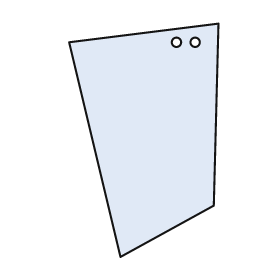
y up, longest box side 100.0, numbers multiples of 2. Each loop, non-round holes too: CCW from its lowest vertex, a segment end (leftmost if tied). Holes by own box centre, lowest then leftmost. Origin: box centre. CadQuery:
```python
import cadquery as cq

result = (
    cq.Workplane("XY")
    .moveTo(-10.0, -50.0)
    .lineTo(30.0, -28.0)
    .lineTo(32.0, 50.0)
    .lineTo(-32.0, 42.0)
    .close()
    .moveTo(14.0, 42.0)
    .circle(2.0)
    .moveTo(22.0, 42.0)
    .circle(2.0)
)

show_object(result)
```